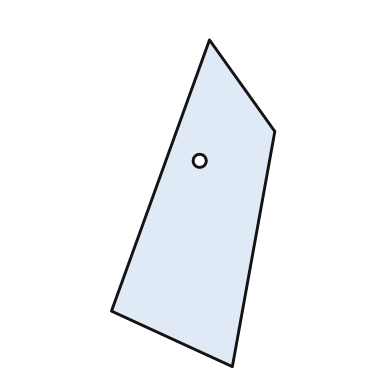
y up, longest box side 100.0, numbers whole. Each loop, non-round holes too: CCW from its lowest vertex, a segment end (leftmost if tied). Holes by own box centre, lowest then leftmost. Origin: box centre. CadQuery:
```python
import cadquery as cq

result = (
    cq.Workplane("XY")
    .moveTo(12.0, -50.0)
    .lineTo(25.0, 22.0)
    .lineTo(5.0, 50.0)
    .lineTo(-25.0, -33.0)
    .close()
    .moveTo(2.0, 13.0)
    .circle(2.0)
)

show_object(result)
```